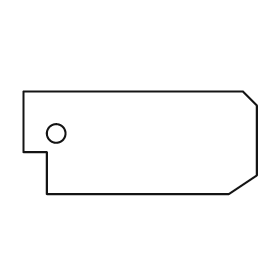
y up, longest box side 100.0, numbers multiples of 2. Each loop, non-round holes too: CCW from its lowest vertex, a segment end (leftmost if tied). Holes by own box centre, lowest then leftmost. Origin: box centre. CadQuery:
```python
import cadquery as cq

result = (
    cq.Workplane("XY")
    .moveTo(-40.0, -22.0)
    .lineTo(38.0, -22.0)
    .lineTo(50.0, -14.0)
    .lineTo(50.0, 16.0)
    .lineTo(44.0, 22.0)
    .lineTo(-50.0, 22.0)
    .lineTo(-50.0, -4.0)
    .lineTo(-40.0, -4.0)
    .close()
    .moveTo(-36.0, 4.0)
    .circle(4.0)
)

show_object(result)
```